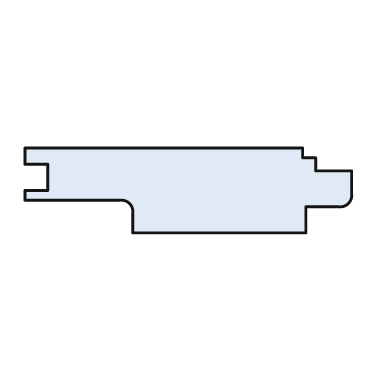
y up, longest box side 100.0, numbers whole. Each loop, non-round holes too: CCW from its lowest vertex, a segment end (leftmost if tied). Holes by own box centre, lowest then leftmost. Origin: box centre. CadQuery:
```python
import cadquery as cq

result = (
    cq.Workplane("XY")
    .moveTo(-17.0, -13.0)
    .lineTo(36.0, -13.0)
    .lineTo(36.0, -5.0)
    .lineTo(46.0, -5.0)
    .threePointArc((49.0, -4.0), (50.0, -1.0))
    .lineTo(50.0, 6.0)
    .lineTo(39.0, 6.0)
    .lineTo(39.0, 10.0)
    .lineTo(35.0, 10.0)
    .lineTo(35.0, 13.0)
    .lineTo(-50.0, 13.0)
    .lineTo(-50.0, 8.0)
    .lineTo(-43.0, 8.0)
    .lineTo(-43.0, 0.0)
    .lineTo(-50.0, 0.0)
    .lineTo(-50.0, -3.0)
    .lineTo(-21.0, -3.0)
    .threePointArc((-18.0, -4.0), (-17.0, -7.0))
    .close()
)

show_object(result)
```